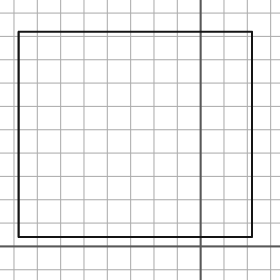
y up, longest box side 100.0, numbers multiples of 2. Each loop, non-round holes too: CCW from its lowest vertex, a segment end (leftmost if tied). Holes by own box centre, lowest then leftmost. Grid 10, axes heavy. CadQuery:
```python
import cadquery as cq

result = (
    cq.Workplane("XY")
    .moveTo(-78.0, 4.0)
    .lineTo(22.0, 4.0)
    .lineTo(22.0, 92.0)
    .lineTo(-78.0, 92.0)
    .close()
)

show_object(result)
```